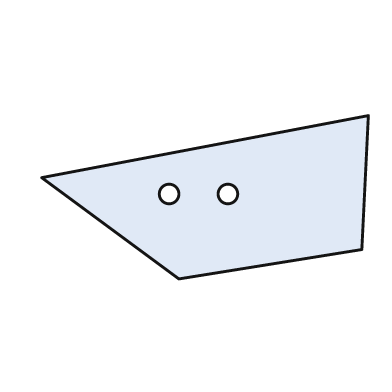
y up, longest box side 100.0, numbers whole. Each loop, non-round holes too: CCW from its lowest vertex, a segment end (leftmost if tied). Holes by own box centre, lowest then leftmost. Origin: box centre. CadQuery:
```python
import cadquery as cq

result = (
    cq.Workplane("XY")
    .moveTo(-8.0, -25.0)
    .lineTo(48.0, -16.0)
    .lineTo(50.0, 25.0)
    .lineTo(-50.0, 6.0)
    .close()
    .moveTo(-11.0, 1.0)
    .circle(3.0)
    .moveTo(7.0, 1.0)
    .circle(3.0)
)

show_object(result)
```